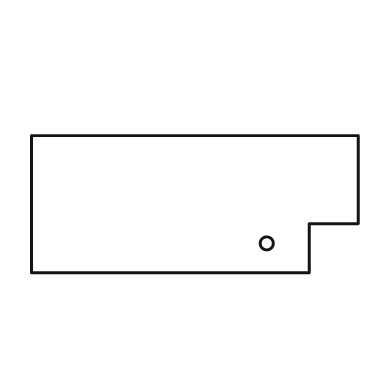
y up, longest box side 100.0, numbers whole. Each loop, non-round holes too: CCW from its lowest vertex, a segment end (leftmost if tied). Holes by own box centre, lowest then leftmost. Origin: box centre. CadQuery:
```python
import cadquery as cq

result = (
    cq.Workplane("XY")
    .moveTo(-50.0, -21.0)
    .lineTo(35.0, -21.0)
    .lineTo(35.0, -6.0)
    .lineTo(50.0, -6.0)
    .lineTo(50.0, 21.0)
    .lineTo(-50.0, 21.0)
    .close()
    .moveTo(22.0, -12.0)
    .circle(2.0)
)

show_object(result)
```